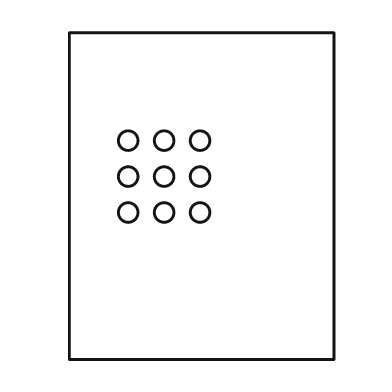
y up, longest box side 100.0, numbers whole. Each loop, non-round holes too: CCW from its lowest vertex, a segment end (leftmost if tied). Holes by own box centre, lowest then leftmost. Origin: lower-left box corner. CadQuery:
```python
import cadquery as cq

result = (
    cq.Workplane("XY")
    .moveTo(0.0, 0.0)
    .lineTo(81.0, 0.0)
    .lineTo(81.0, 100.0)
    .lineTo(0.0, 100.0)
    .close()
    .moveTo(18.0, 45.0)
    .circle(3.0)
    .moveTo(29.0, 45.0)
    .circle(3.0)
    .moveTo(40.0, 45.0)
    .circle(3.0)
    .moveTo(18.0, 56.0)
    .circle(3.0)
    .moveTo(29.0, 56.0)
    .circle(3.0)
    .moveTo(40.0, 56.0)
    .circle(3.0)
    .moveTo(18.0, 67.0)
    .circle(3.0)
    .moveTo(29.0, 67.0)
    .circle(3.0)
    .moveTo(40.0, 67.0)
    .circle(3.0)
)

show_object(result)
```